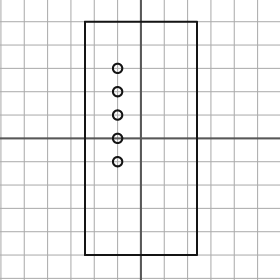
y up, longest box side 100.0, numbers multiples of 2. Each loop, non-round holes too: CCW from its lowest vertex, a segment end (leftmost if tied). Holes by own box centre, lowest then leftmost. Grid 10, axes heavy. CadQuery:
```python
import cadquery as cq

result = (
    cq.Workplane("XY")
    .moveTo(-24.0, -50.0)
    .lineTo(24.0, -50.0)
    .lineTo(24.0, 50.0)
    .lineTo(-24.0, 50.0)
    .close()
    .moveTo(-10.0, -10.0)
    .circle(2.0)
    .moveTo(-10.0, 0.0)
    .circle(2.0)
    .moveTo(-10.0, 10.0)
    .circle(2.0)
    .moveTo(-10.0, 20.0)
    .circle(2.0)
    .moveTo(-10.0, 30.0)
    .circle(2.0)
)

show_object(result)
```